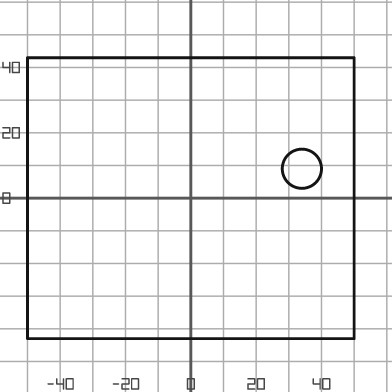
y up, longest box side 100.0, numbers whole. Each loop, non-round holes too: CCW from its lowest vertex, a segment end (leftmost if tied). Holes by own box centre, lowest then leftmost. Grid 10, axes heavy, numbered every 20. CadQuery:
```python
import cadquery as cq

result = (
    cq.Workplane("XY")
    .moveTo(-50.0, -43.0)
    .lineTo(50.0, -43.0)
    .lineTo(50.0, 43.0)
    .lineTo(-50.0, 43.0)
    .close()
    .moveTo(34.0, 9.0)
    .circle(6.0)
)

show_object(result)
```